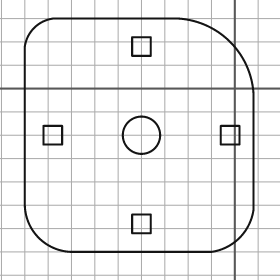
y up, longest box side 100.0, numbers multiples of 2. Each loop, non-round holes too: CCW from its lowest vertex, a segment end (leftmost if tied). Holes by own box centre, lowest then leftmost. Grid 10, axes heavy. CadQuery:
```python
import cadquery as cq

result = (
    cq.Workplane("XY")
    .moveTo(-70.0, -70.0)
    .lineTo(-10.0, -70.0)
    .threePointArc((2.0, -64.0), (8.0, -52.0))
    .lineTo(8.0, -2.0)
    .threePointArc((-2.0, 20.0), (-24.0, 30.0))
    .lineTo(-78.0, 30.0)
    .threePointArc((-86.0, 26.0), (-90.0, 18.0))
    .lineTo(-90.0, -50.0)
    .threePointArc((-84.0, -64.0), (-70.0, -70.0))
    .close()
    .moveTo(-44.0, -62.0)
    .lineTo(-36.0, -62.0)
    .lineTo(-36.0, -54.0)
    .lineTo(-44.0, -54.0)
    .close()
    .moveTo(-82.0, -24.0)
    .lineTo(-74.0, -24.0)
    .lineTo(-74.0, -16.0)
    .lineTo(-82.0, -16.0)
    .close()
    .moveTo(-40.0, -20.0)
    .circle(8.0)
    .moveTo(-6.0, -24.0)
    .lineTo(2.0, -24.0)
    .lineTo(2.0, -16.0)
    .lineTo(-6.0, -16.0)
    .close()
    .moveTo(-44.0, 14.0)
    .lineTo(-36.0, 14.0)
    .lineTo(-36.0, 22.0)
    .lineTo(-44.0, 22.0)
    .close()
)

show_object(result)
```